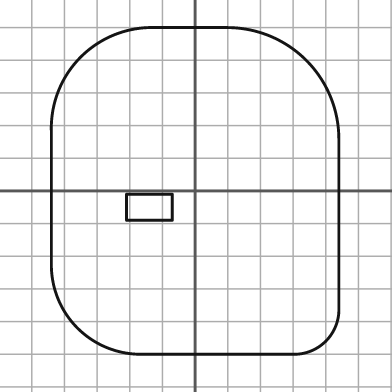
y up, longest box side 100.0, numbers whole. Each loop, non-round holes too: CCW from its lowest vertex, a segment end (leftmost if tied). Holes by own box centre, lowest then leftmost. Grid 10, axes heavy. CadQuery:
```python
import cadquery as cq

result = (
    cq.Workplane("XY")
    .moveTo(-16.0, -50.0)
    .lineTo(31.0, -50.0)
    .threePointArc((40.0, -46.0), (44.0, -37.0))
    .lineTo(44.0, 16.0)
    .threePointArc((34.0, 40.0), (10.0, 50.0))
    .lineTo(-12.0, 50.0)
    .threePointArc((-35.0, 41.0), (-44.0, 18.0))
    .lineTo(-44.0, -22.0)
    .threePointArc((-36.0, -42.0), (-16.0, -50.0))
    .close()
    .moveTo(-21.0, -9.0)
    .lineTo(-7.0, -9.0)
    .lineTo(-7.0, -1.0)
    .lineTo(-21.0, -1.0)
    .close()
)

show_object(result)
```